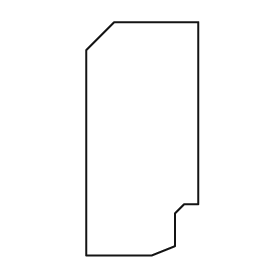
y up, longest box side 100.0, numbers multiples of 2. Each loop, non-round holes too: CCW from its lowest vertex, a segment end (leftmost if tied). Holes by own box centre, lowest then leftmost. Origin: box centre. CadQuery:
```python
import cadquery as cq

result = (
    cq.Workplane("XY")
    .moveTo(-24.0, -50.0)
    .lineTo(4.0, -50.0)
    .lineTo(14.0, -46.0)
    .lineTo(14.0, -32.0)
    .lineTo(18.0, -28.0)
    .lineTo(24.0, -28.0)
    .lineTo(24.0, 50.0)
    .lineTo(-12.0, 50.0)
    .lineTo(-24.0, 38.0)
    .close()
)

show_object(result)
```